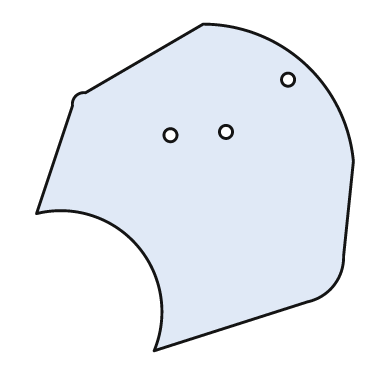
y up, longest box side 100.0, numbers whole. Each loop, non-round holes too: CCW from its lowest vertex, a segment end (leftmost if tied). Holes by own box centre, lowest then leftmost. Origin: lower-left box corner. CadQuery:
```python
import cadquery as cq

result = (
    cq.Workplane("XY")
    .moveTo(36.0, 0.0)
    .lineTo(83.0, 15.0)
    .threePointArc((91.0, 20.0), (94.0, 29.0))
    .lineTo(97.0, 58.0)
    .threePointArc((82.0, 88.0), (51.0, 100.0))
    .lineTo(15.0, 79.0)
    .threePointArc((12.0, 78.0), (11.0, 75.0))
    .lineTo(0.0, 42.0)
    .threePointArc((31.0, 32.0), (36.0, 0.0))
    .close()
    .moveTo(41.0, 66.0)
    .circle(2.0)
    .moveTo(58.0, 67.0)
    .circle(2.0)
    .moveTo(77.0, 83.0)
    .circle(2.0)
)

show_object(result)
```